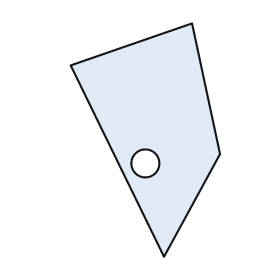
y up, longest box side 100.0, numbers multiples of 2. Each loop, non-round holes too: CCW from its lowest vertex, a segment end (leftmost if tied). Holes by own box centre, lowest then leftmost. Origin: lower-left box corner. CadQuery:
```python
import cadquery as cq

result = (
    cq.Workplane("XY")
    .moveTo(40.0, 0.0)
    .lineTo(64.0, 44.0)
    .lineTo(52.0, 100.0)
    .lineTo(0.0, 82.0)
    .close()
    .moveTo(32.0, 40.0)
    .circle(6.0)
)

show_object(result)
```